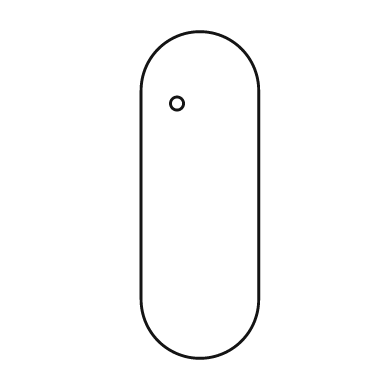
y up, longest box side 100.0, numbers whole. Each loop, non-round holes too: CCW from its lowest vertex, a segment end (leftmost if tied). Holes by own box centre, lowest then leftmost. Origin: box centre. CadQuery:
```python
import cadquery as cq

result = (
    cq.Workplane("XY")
    .moveTo(-18.0, -32.0)
    .threePointArc((0.0, -50.0), (18.0, -32.0))
    .lineTo(18.0, 32.0)
    .threePointArc((0.0, 50.0), (-18.0, 32.0))
    .close()
    .moveTo(-7.0, 28.0)
    .circle(2.0)
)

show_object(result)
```